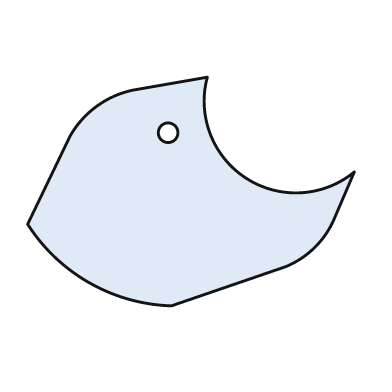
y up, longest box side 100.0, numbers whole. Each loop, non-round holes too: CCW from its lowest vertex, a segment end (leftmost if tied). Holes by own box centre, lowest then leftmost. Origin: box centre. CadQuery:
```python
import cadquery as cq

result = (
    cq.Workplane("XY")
    .moveTo(-6.0, -35.0)
    .lineTo(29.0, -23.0)
    .threePointArc((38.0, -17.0), (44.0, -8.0))
    .lineTo(50.0, 6.0)
    .threePointArc((17.0, 4.0), (5.0, 35.0))
    .lineTo(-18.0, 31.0)
    .threePointArc((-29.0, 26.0), (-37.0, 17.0))
    .lineTo(-50.0, -10.0)
    .threePointArc((-31.0, -28.0), (-6.0, -35.0))
    .close()
    .moveTo(-7.0, 18.0)
    .circle(3.0)
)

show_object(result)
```